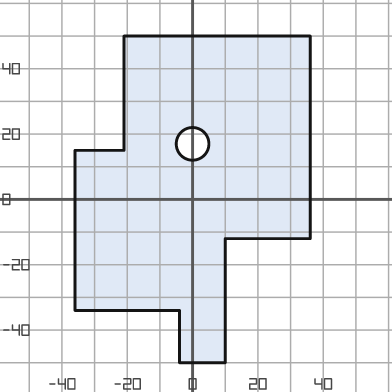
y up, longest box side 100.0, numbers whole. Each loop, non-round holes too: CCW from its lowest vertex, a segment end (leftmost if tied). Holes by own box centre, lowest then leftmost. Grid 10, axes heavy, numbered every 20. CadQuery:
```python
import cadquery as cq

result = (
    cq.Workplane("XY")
    .moveTo(-4.0, -50.0)
    .lineTo(10.0, -50.0)
    .lineTo(10.0, -12.0)
    .lineTo(36.0, -12.0)
    .lineTo(36.0, 50.0)
    .lineTo(-21.0, 50.0)
    .lineTo(-21.0, 15.0)
    .lineTo(-36.0, 15.0)
    .lineTo(-36.0, -34.0)
    .lineTo(-4.0, -34.0)
    .close()
    .moveTo(0.0, 17.0)
    .circle(5.0)
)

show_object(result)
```